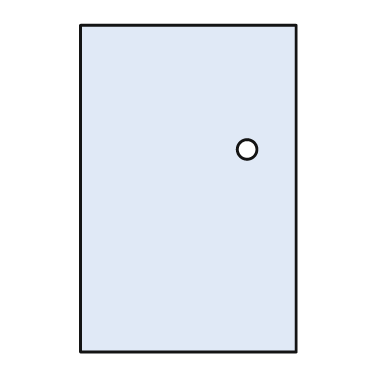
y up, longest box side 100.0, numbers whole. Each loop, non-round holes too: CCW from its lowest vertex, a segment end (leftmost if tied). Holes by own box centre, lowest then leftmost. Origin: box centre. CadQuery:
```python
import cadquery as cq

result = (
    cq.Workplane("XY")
    .moveTo(-33.0, -50.0)
    .lineTo(33.0, -50.0)
    .lineTo(33.0, 50.0)
    .lineTo(-33.0, 50.0)
    .close()
    .moveTo(18.0, 12.0)
    .circle(3.0)
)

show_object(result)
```